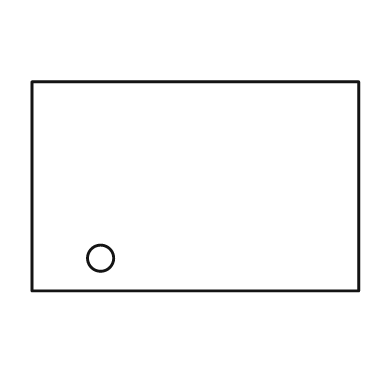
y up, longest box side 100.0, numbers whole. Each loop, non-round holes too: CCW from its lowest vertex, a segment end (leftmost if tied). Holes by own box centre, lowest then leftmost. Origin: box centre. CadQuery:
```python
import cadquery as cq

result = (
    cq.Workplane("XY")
    .moveTo(-50.0, -32.0)
    .lineTo(50.0, -32.0)
    .lineTo(50.0, 32.0)
    .lineTo(-50.0, 32.0)
    .close()
    .moveTo(-29.0, -22.0)
    .circle(4.0)
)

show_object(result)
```